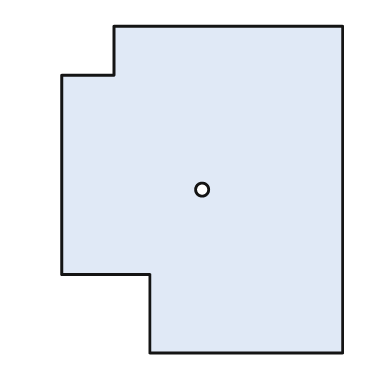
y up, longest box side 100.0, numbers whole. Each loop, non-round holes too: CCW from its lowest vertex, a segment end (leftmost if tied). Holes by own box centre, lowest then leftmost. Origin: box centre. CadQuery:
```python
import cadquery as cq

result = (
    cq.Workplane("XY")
    .moveTo(-16.0, -50.0)
    .lineTo(43.0, -50.0)
    .lineTo(43.0, 50.0)
    .lineTo(-27.0, 50.0)
    .lineTo(-27.0, 35.0)
    .lineTo(-43.0, 35.0)
    .lineTo(-43.0, -26.0)
    .lineTo(-16.0, -26.0)
    .close()
    .moveTo(0.0, 0.0)
    .circle(2.0)
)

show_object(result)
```